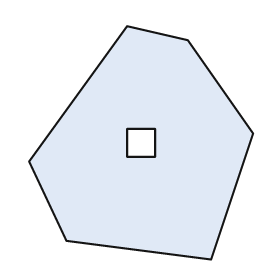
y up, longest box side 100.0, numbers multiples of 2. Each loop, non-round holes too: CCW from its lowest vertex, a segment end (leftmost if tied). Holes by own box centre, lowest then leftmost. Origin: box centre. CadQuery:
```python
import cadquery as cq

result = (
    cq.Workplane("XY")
    .moveTo(30.0, -50.0)
    .lineTo(48.0, 4.0)
    .lineTo(20.0, 44.0)
    .lineTo(-6.0, 50.0)
    .lineTo(-48.0, -8.0)
    .lineTo(-32.0, -42.0)
    .close()
    .moveTo(-6.0, -6.0)
    .lineTo(6.0, -6.0)
    .lineTo(6.0, 6.0)
    .lineTo(-6.0, 6.0)
    .close()
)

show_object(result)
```